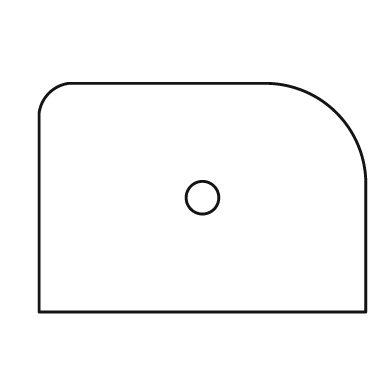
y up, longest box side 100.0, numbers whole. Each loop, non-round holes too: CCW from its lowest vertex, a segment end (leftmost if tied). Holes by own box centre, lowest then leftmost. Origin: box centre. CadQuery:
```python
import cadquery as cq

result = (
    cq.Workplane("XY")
    .moveTo(-50.0, -35.0)
    .lineTo(50.0, -35.0)
    .lineTo(50.0, 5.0)
    .threePointArc((41.0, 26.0), (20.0, 35.0))
    .lineTo(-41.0, 35.0)
    .threePointArc((-47.0, 32.0), (-50.0, 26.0))
    .close()
    .moveTo(0.0, 0.0)
    .circle(5.0)
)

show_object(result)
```